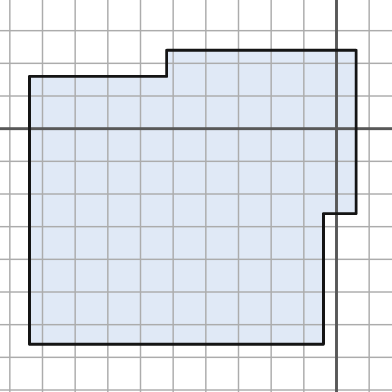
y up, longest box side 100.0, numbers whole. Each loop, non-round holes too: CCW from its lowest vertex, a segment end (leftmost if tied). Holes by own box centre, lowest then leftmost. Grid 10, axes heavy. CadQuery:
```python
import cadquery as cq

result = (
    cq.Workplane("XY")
    .moveTo(-94.0, -66.0)
    .lineTo(-4.0, -66.0)
    .lineTo(-4.0, -26.0)
    .lineTo(6.0, -26.0)
    .lineTo(6.0, 24.0)
    .lineTo(-52.0, 24.0)
    .lineTo(-52.0, 16.0)
    .lineTo(-94.0, 16.0)
    .close()
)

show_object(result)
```